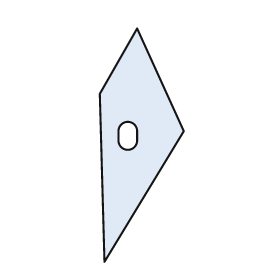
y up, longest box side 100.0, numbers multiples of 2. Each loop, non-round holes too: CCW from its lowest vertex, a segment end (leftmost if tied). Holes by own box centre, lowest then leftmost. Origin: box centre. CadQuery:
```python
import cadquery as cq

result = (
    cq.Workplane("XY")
    .moveTo(-16.0, -50.0)
    .lineTo(18.0, 6.0)
    .lineTo(-2.0, 50.0)
    .lineTo(-18.0, 22.0)
    .close()
    .moveTo(-10.0, 2.0)
    .threePointArc((-6.0, -2.0), (-2.0, 2.0))
    .lineTo(-2.0, 6.0)
    .threePointArc((-6.0, 10.0), (-10.0, 6.0))
    .close()
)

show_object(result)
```